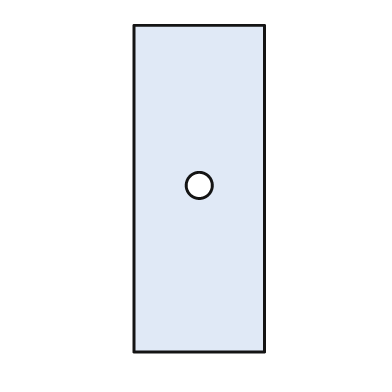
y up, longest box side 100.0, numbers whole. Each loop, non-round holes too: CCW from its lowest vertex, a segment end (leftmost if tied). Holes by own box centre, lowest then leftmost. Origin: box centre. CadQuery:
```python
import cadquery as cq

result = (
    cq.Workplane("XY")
    .moveTo(-20.0, -50.0)
    .lineTo(20.0, -50.0)
    .lineTo(20.0, 50.0)
    .lineTo(-20.0, 50.0)
    .close()
    .moveTo(0.0, 1.0)
    .circle(4.0)
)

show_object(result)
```